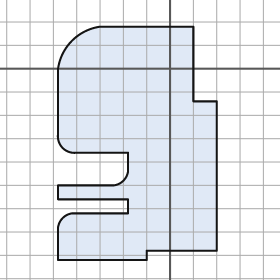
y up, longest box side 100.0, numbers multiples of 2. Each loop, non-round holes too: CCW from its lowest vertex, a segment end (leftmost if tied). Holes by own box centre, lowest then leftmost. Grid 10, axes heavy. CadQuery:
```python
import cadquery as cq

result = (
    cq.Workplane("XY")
    .moveTo(-48.0, -82.0)
    .lineTo(-10.0, -82.0)
    .lineTo(-10.0, -78.0)
    .lineTo(20.0, -78.0)
    .lineTo(20.0, -14.0)
    .lineTo(10.0, -14.0)
    .lineTo(10.0, 18.0)
    .lineTo(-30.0, 18.0)
    .threePointArc((-42.0, 12.0), (-48.0, 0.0))
    .lineTo(-48.0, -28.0)
    .threePointArc((-46.0, -34.0), (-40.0, -36.0))
    .lineTo(-18.0, -36.0)
    .lineTo(-18.0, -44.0)
    .threePointArc((-20.0, -48.0), (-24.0, -50.0))
    .lineTo(-48.0, -50.0)
    .lineTo(-48.0, -56.0)
    .lineTo(-18.0, -56.0)
    .lineTo(-18.0, -62.0)
    .lineTo(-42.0, -62.0)
    .threePointArc((-46.0, -64.0), (-48.0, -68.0))
    .close()
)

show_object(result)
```